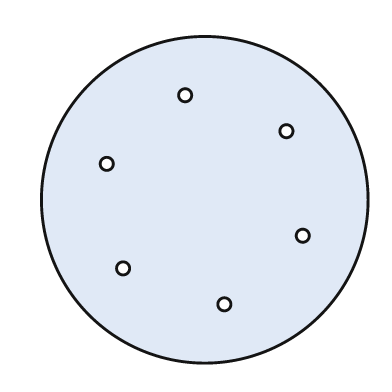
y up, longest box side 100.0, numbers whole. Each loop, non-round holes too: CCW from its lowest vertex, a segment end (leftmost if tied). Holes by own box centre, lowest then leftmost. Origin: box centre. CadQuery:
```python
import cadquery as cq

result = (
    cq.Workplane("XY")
    .moveTo(0.0, 0.0)
    .circle(50.0)
    .moveTo(6.0, -32.0)
    .circle(2.0)
    .moveTo(-25.0, -21.0)
    .circle(2.0)
    .moveTo(30.0, -11.0)
    .circle(2.0)
    .moveTo(-30.0, 11.0)
    .circle(2.0)
    .moveTo(25.0, 21.0)
    .circle(2.0)
    .moveTo(-6.0, 32.0)
    .circle(2.0)
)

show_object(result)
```